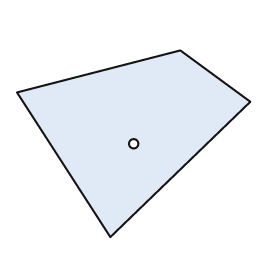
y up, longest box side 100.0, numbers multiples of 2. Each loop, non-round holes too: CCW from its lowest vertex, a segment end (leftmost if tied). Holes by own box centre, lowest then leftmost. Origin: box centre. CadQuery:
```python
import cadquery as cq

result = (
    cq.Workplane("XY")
    .moveTo(-10.0, -40.0)
    .lineTo(50.0, 18.0)
    .lineTo(20.0, 40.0)
    .lineTo(-50.0, 22.0)
    .close()
    .moveTo(0.0, 0.0)
    .circle(2.0)
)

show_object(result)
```